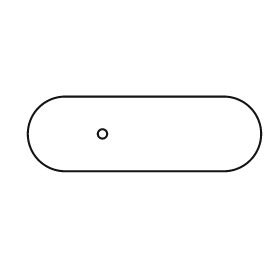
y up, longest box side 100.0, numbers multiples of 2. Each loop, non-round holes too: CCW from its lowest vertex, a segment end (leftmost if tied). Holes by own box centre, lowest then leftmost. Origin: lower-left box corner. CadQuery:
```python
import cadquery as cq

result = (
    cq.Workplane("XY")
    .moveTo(16.0, 0.0)
    .lineTo(84.0, 0.0)
    .threePointArc((100.0, 16.0), (84.0, 32.0))
    .lineTo(16.0, 32.0)
    .threePointArc((0.0, 16.0), (16.0, 0.0))
    .close()
    .moveTo(32.0, 16.0)
    .circle(2.0)
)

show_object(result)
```